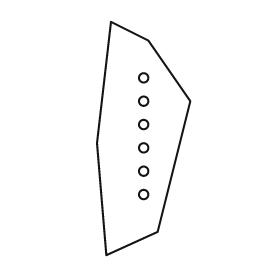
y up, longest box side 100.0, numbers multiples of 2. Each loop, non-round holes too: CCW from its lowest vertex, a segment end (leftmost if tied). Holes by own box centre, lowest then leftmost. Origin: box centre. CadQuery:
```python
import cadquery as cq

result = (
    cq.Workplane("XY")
    .moveTo(-16.0, -50.0)
    .lineTo(6.0, -40.0)
    .lineTo(20.0, 16.0)
    .lineTo(2.0, 42.0)
    .lineTo(-14.0, 50.0)
    .lineTo(-20.0, -2.0)
    .close()
    .moveTo(0.0, -24.0)
    .circle(2.0)
    .moveTo(0.0, -14.0)
    .circle(2.0)
    .moveTo(0.0, -4.0)
    .circle(2.0)
    .moveTo(0.0, 6.0)
    .circle(2.0)
    .moveTo(0.0, 16.0)
    .circle(2.0)
    .moveTo(0.0, 26.0)
    .circle(2.0)
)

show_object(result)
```